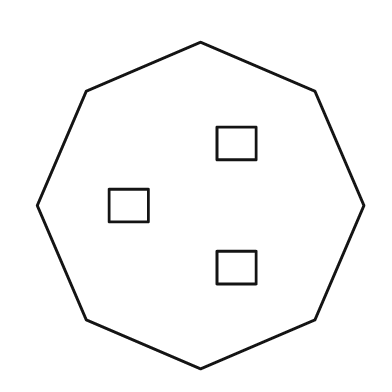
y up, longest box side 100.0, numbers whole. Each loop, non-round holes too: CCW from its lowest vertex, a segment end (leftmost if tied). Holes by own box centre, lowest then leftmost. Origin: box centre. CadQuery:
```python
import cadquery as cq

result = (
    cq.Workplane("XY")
    .moveTo(0.0, -50.0)
    .lineTo(35.0, -35.0)
    .lineTo(50.0, 0.0)
    .lineTo(35.0, 35.0)
    .lineTo(0.0, 50.0)
    .lineTo(-35.0, 35.0)
    .lineTo(-50.0, 0.0)
    .lineTo(-35.0, -35.0)
    .close()
    .moveTo(5.0, -24.0)
    .lineTo(17.0, -24.0)
    .lineTo(17.0, -14.0)
    .lineTo(5.0, -14.0)
    .close()
    .moveTo(-28.0, -5.0)
    .lineTo(-16.0, -5.0)
    .lineTo(-16.0, 5.0)
    .lineTo(-28.0, 5.0)
    .close()
    .moveTo(5.0, 14.0)
    .lineTo(17.0, 14.0)
    .lineTo(17.0, 24.0)
    .lineTo(5.0, 24.0)
    .close()
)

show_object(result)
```